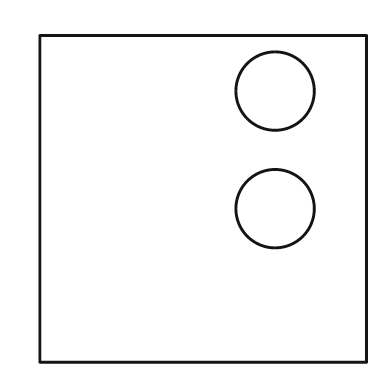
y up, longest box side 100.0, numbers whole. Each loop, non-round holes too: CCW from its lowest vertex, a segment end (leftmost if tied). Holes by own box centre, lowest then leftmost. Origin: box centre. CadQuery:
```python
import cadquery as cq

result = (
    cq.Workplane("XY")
    .moveTo(-50.0, -50.0)
    .lineTo(50.0, -50.0)
    .lineTo(50.0, 50.0)
    .lineTo(-50.0, 50.0)
    .close()
    .moveTo(22.0, -3.0)
    .circle(12.0)
    .moveTo(22.0, 33.0)
    .circle(12.0)
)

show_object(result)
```